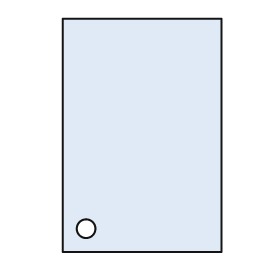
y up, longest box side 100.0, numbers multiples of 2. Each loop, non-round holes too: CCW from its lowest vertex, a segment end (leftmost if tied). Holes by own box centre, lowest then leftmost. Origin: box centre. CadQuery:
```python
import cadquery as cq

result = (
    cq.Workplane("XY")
    .moveTo(-34.0, -50.0)
    .lineTo(34.0, -50.0)
    .lineTo(34.0, 50.0)
    .lineTo(-34.0, 50.0)
    .close()
    .moveTo(-24.0, -40.0)
    .circle(4.0)
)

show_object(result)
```